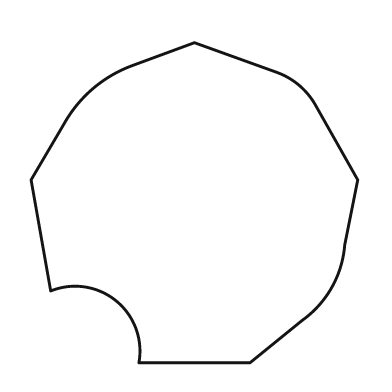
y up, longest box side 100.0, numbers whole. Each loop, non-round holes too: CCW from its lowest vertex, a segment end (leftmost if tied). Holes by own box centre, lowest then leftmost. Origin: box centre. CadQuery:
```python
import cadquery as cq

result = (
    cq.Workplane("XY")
    .moveTo(-17.0, -49.0)
    .lineTo(17.0, -49.0)
    .lineTo(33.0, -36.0)
    .threePointArc((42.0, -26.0), (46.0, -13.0))
    .lineTo(50.0, 7.0)
    .lineTo(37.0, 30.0)
    .threePointArc((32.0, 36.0), (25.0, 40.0))
    .lineTo(0.0, 49.0)
    .lineTo(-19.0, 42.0)
    .threePointArc((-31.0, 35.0), (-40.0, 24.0))
    .lineTo(-50.0, 7.0)
    .lineTo(-44.0, -27.0)
    .threePointArc((-24.0, -30.0), (-17.0, -49.0))
    .close()
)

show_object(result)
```